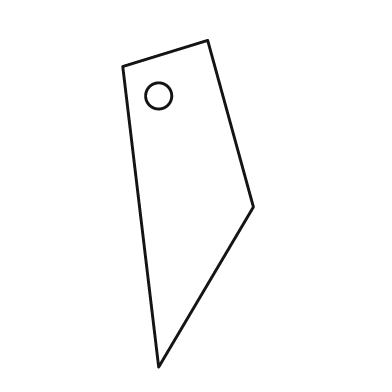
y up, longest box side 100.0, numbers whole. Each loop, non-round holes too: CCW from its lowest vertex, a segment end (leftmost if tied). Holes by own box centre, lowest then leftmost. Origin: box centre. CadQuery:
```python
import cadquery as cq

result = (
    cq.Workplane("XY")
    .moveTo(-9.0, -50.0)
    .lineTo(20.0, -1.0)
    .lineTo(6.0, 50.0)
    .lineTo(-20.0, 42.0)
    .close()
    .moveTo(-9.0, 33.0)
    .circle(4.0)
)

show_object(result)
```